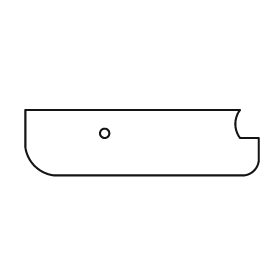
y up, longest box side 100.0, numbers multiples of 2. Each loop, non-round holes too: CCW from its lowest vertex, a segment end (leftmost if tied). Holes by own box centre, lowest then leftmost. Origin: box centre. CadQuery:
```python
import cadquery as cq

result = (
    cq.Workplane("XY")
    .moveTo(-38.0, -14.0)
    .lineTo(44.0, -14.0)
    .threePointArc((48.0, -12.0), (50.0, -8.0))
    .lineTo(50.0, 2.0)
    .lineTo(42.0, 2.0)
    .threePointArc((40.0, 8.0), (42.0, 14.0))
    .lineTo(-50.0, 14.0)
    .lineTo(-50.0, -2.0)
    .threePointArc((-46.0, -10.0), (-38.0, -14.0))
    .close()
    .moveTo(-16.0, 4.0)
    .circle(2.0)
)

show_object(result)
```